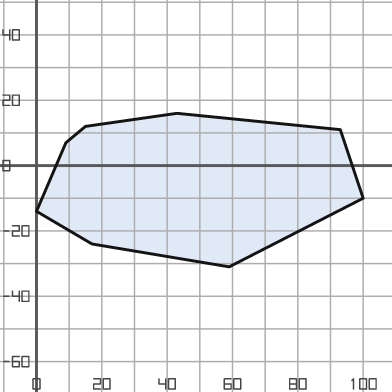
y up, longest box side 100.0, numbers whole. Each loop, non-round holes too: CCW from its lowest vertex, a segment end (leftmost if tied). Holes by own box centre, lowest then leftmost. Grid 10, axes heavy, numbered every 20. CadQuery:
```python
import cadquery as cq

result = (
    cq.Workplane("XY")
    .moveTo(59.0, -31.0)
    .lineTo(100.0, -10.0)
    .lineTo(93.0, 11.0)
    .lineTo(43.0, 16.0)
    .lineTo(15.0, 12.0)
    .lineTo(9.0, 7.0)
    .lineTo(0.0, -14.0)
    .lineTo(17.0, -24.0)
    .close()
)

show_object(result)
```